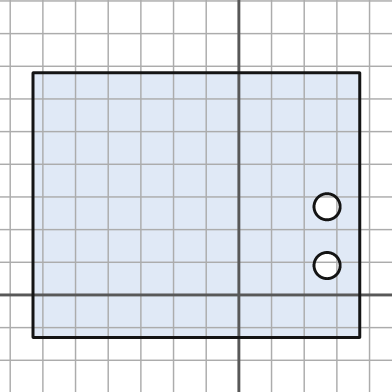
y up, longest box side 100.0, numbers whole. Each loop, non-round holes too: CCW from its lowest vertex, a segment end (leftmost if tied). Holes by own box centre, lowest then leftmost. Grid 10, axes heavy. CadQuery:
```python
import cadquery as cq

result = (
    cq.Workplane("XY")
    .moveTo(-63.0, -13.0)
    .lineTo(37.0, -13.0)
    .lineTo(37.0, 68.0)
    .lineTo(-63.0, 68.0)
    .close()
    .moveTo(27.0, 9.0)
    .circle(4.0)
    .moveTo(27.0, 27.0)
    .circle(4.0)
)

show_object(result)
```